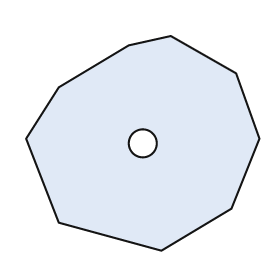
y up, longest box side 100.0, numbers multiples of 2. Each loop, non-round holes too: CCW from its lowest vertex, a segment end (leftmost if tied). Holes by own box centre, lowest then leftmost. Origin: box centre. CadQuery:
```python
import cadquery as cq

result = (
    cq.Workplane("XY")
    .moveTo(8.0, -46.0)
    .lineTo(38.0, -28.0)
    .lineTo(50.0, 2.0)
    .lineTo(40.0, 30.0)
    .lineTo(12.0, 46.0)
    .lineTo(-6.0, 42.0)
    .lineTo(-36.0, 24.0)
    .lineTo(-50.0, 2.0)
    .lineTo(-36.0, -34.0)
    .close()
    .moveTo(0.0, 0.0)
    .circle(6.0)
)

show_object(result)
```